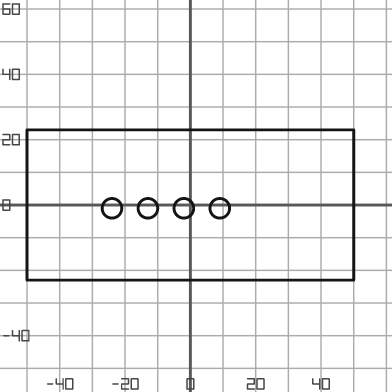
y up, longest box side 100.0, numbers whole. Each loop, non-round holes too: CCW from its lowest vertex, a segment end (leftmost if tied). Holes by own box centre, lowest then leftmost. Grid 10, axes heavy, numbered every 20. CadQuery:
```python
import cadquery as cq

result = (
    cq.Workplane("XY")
    .moveTo(-50.0, -23.0)
    .lineTo(50.0, -23.0)
    .lineTo(50.0, 23.0)
    .lineTo(-50.0, 23.0)
    .close()
    .moveTo(-24.0, -1.0)
    .circle(3.0)
    .moveTo(-13.0, -1.0)
    .circle(3.0)
    .moveTo(-2.0, -1.0)
    .circle(3.0)
    .moveTo(9.0, -1.0)
    .circle(3.0)
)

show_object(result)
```